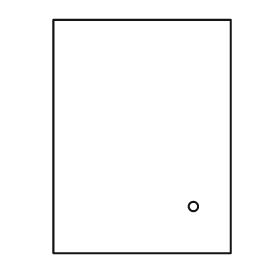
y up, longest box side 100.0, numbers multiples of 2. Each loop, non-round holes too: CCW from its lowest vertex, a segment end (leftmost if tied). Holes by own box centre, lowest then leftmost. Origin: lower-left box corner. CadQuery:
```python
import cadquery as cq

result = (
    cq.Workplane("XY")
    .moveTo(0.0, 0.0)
    .lineTo(76.0, 0.0)
    .lineTo(76.0, 100.0)
    .lineTo(0.0, 100.0)
    .close()
    .moveTo(60.0, 20.0)
    .circle(2.0)
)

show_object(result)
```